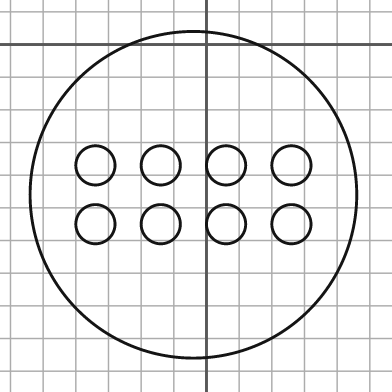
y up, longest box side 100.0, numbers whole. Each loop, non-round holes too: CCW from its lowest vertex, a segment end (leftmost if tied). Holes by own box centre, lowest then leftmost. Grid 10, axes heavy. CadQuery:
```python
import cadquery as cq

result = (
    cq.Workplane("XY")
    .moveTo(-4.0, -46.0)
    .circle(50.0)
    .moveTo(-34.0, -55.0)
    .circle(6.0)
    .moveTo(-14.0, -55.0)
    .circle(6.0)
    .moveTo(6.0, -55.0)
    .circle(6.0)
    .moveTo(26.0, -55.0)
    .circle(6.0)
    .moveTo(-34.0, -37.0)
    .circle(6.0)
    .moveTo(-14.0, -37.0)
    .circle(6.0)
    .moveTo(6.0, -37.0)
    .circle(6.0)
    .moveTo(26.0, -37.0)
    .circle(6.0)
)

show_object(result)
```